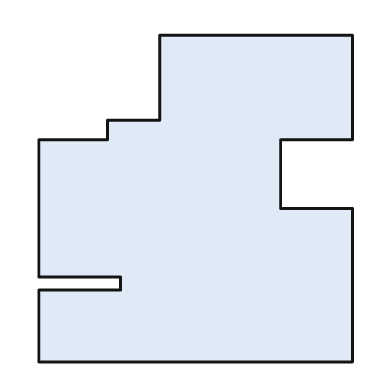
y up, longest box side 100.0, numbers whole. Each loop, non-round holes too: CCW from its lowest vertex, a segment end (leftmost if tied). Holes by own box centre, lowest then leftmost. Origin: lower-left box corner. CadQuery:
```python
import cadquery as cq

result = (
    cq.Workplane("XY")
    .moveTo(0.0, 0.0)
    .lineTo(96.0, 0.0)
    .lineTo(96.0, 47.0)
    .lineTo(74.0, 47.0)
    .lineTo(74.0, 68.0)
    .lineTo(96.0, 68.0)
    .lineTo(96.0, 100.0)
    .lineTo(37.0, 100.0)
    .lineTo(37.0, 74.0)
    .lineTo(21.0, 74.0)
    .lineTo(21.0, 68.0)
    .lineTo(0.0, 68.0)
    .lineTo(0.0, 26.0)
    .lineTo(25.0, 26.0)
    .lineTo(25.0, 22.0)
    .lineTo(0.0, 22.0)
    .close()
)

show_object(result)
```